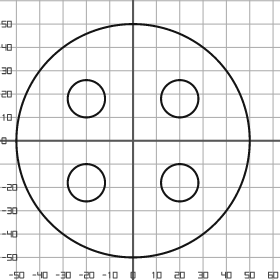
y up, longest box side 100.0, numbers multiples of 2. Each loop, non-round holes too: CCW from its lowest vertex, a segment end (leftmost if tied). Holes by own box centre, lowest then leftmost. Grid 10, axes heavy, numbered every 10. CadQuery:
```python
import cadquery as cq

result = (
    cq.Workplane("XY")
    .moveTo(0.0, 0.0)
    .circle(50.0)
    .moveTo(-20.0, -18.0)
    .circle(8.0)
    .moveTo(20.0, -18.0)
    .circle(8.0)
    .moveTo(-20.0, 18.0)
    .circle(8.0)
    .moveTo(20.0, 18.0)
    .circle(8.0)
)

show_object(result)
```